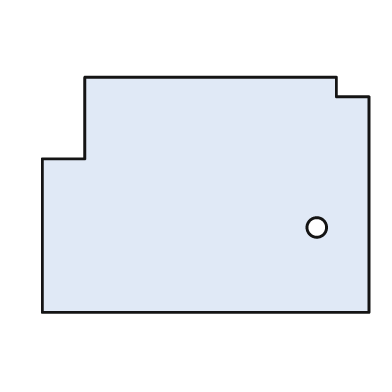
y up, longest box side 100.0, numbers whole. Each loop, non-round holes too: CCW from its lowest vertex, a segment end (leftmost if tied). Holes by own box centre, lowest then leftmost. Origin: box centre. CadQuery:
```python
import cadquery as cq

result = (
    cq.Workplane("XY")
    .moveTo(-50.0, -36.0)
    .lineTo(50.0, -36.0)
    .lineTo(50.0, 30.0)
    .lineTo(40.0, 30.0)
    .lineTo(40.0, 36.0)
    .lineTo(-37.0, 36.0)
    .lineTo(-37.0, 11.0)
    .lineTo(-50.0, 11.0)
    .close()
    .moveTo(34.0, -10.0)
    .circle(3.0)
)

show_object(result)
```